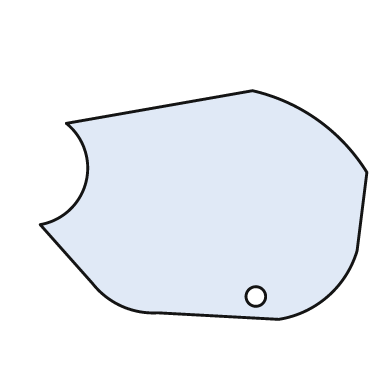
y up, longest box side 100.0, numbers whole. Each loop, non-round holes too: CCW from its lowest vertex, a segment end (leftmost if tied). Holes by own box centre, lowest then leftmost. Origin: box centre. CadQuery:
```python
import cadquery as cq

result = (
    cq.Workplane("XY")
    .moveTo(23.0, -35.0)
    .threePointArc((38.0, -28.0), (47.0, -14.0))
    .lineTo(50.0, 10.0)
    .threePointArc((35.0, 26.0), (15.0, 35.0))
    .lineTo(-42.0, 25.0)
    .threePointArc((-36.0, 7.0), (-50.0, -6.0))
    .lineTo(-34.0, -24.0)
    .threePointArc((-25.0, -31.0), (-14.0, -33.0))
    .close()
    .moveTo(16.0, -28.0)
    .circle(3.0)
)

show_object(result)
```